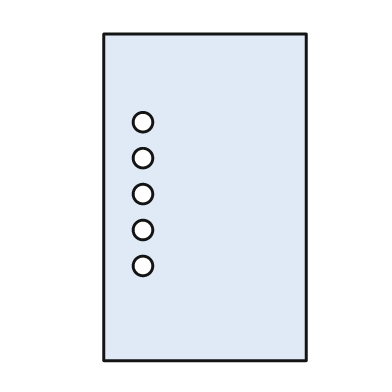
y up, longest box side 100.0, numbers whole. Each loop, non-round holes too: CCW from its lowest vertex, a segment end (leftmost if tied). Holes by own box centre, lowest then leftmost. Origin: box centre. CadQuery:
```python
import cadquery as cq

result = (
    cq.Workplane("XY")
    .moveTo(-31.0, -50.0)
    .lineTo(31.0, -50.0)
    .lineTo(31.0, 50.0)
    .lineTo(-31.0, 50.0)
    .close()
    .moveTo(-19.0, -21.0)
    .circle(3.0)
    .moveTo(-19.0, -10.0)
    .circle(3.0)
    .moveTo(-19.0, 1.0)
    .circle(3.0)
    .moveTo(-19.0, 12.0)
    .circle(3.0)
    .moveTo(-19.0, 23.0)
    .circle(3.0)
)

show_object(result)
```